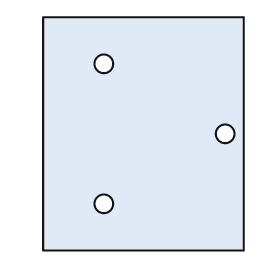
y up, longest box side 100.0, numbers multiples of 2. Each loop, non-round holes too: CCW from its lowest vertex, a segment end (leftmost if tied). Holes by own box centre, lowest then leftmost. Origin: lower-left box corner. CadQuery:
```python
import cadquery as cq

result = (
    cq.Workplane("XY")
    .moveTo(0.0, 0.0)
    .lineTo(86.0, 0.0)
    .lineTo(86.0, 100.0)
    .lineTo(0.0, 100.0)
    .close()
    .moveTo(26.0, 20.0)
    .circle(4.0)
    .moveTo(78.0, 50.0)
    .circle(4.0)
    .moveTo(26.0, 80.0)
    .circle(4.0)
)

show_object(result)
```